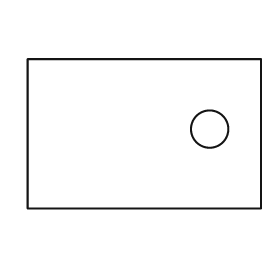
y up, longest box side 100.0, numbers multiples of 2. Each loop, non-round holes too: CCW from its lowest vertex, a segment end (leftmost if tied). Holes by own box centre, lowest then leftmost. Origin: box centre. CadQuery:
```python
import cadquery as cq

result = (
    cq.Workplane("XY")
    .moveTo(-50.0, -32.0)
    .lineTo(50.0, -32.0)
    .lineTo(50.0, 32.0)
    .lineTo(-50.0, 32.0)
    .close()
    .moveTo(28.0, 2.0)
    .circle(8.0)
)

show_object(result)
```